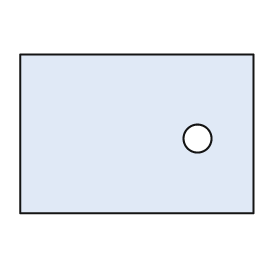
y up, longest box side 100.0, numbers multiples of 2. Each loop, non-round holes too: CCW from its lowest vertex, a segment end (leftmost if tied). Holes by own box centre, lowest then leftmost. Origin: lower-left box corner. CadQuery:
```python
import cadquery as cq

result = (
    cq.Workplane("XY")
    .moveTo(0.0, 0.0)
    .lineTo(100.0, 0.0)
    .lineTo(100.0, 68.0)
    .lineTo(0.0, 68.0)
    .close()
    .moveTo(76.0, 32.0)
    .circle(6.0)
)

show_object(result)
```